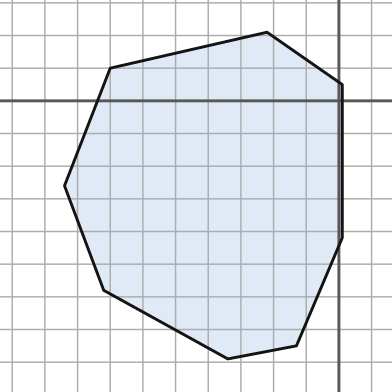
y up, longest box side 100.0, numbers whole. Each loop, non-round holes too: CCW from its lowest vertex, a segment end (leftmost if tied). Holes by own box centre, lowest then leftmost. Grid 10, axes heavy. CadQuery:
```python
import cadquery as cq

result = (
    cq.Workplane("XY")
    .moveTo(-34.0, -79.0)
    .lineTo(-13.0, -75.0)
    .lineTo(1.0, -42.0)
    .lineTo(1.0, 5.0)
    .lineTo(-22.0, 21.0)
    .lineTo(-70.0, 10.0)
    .lineTo(-84.0, -26.0)
    .lineTo(-72.0, -58.0)
    .close()
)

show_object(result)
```